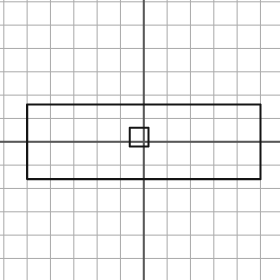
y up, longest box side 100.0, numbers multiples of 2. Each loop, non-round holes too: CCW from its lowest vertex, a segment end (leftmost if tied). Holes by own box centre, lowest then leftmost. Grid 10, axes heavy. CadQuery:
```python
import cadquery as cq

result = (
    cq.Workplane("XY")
    .moveTo(-50.0, -16.0)
    .lineTo(50.0, -16.0)
    .lineTo(50.0, 16.0)
    .lineTo(-50.0, 16.0)
    .close()
    .moveTo(-6.0, -2.0)
    .lineTo(2.0, -2.0)
    .lineTo(2.0, 6.0)
    .lineTo(-6.0, 6.0)
    .close()
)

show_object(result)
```